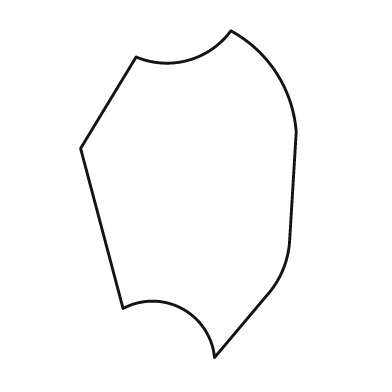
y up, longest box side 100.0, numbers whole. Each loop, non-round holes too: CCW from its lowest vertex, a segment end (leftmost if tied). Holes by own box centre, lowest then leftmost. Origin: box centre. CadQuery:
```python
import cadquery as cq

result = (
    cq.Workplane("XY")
    .moveTo(8.0, -50.0)
    .lineTo(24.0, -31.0)
    .threePointArc((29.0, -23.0), (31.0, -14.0))
    .lineTo(33.0, 19.0)
    .threePointArc((27.0, 37.0), (13.0, 50.0))
    .threePointArc((0.0, 41.0), (-16.0, 42.0))
    .lineTo(-33.0, 14.0)
    .lineTo(-20.0, -35.0)
    .threePointArc((-2.0, -35.0), (8.0, -50.0))
    .close()
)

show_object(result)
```